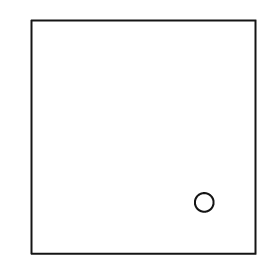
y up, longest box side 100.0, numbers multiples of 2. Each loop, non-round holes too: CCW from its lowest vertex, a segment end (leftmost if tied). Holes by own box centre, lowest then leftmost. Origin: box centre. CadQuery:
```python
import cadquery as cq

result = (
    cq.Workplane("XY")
    .moveTo(-48.0, -50.0)
    .lineTo(48.0, -50.0)
    .lineTo(48.0, 50.0)
    .lineTo(-48.0, 50.0)
    .close()
    .moveTo(26.0, -28.0)
    .circle(4.0)
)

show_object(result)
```